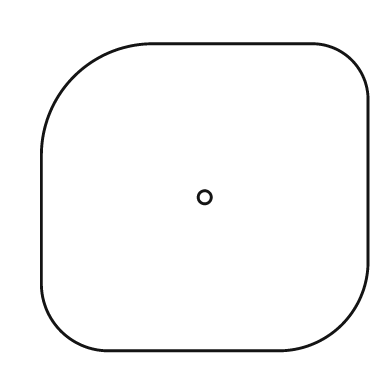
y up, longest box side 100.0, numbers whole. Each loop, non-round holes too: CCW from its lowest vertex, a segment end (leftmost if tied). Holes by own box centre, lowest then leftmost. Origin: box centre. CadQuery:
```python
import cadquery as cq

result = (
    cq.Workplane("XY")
    .moveTo(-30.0, -47.0)
    .lineTo(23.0, -47.0)
    .threePointArc((42.0, -39.0), (50.0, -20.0))
    .lineTo(50.0, 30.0)
    .threePointArc((45.0, 42.0), (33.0, 47.0))
    .lineTo(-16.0, 47.0)
    .threePointArc((-40.0, 37.0), (-50.0, 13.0))
    .lineTo(-50.0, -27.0)
    .threePointArc((-44.0, -41.0), (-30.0, -47.0))
    .close()
    .moveTo(0.0, 0.0)
    .circle(2.0)
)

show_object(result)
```